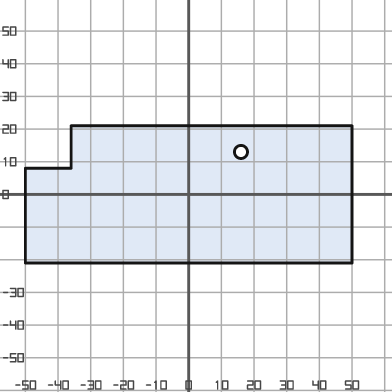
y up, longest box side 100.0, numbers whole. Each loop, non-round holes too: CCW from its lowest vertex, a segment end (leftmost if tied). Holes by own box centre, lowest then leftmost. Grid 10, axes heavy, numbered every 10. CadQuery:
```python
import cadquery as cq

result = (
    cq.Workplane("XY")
    .moveTo(-50.0, -21.0)
    .lineTo(50.0, -21.0)
    .lineTo(50.0, 21.0)
    .lineTo(-36.0, 21.0)
    .lineTo(-36.0, 8.0)
    .lineTo(-50.0, 8.0)
    .close()
    .moveTo(16.0, 13.0)
    .circle(2.0)
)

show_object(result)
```